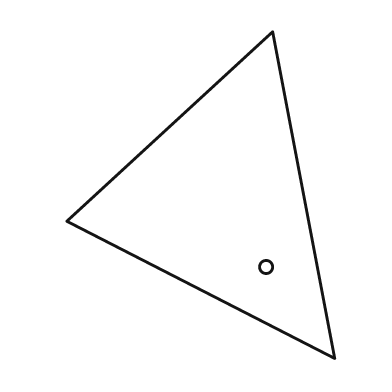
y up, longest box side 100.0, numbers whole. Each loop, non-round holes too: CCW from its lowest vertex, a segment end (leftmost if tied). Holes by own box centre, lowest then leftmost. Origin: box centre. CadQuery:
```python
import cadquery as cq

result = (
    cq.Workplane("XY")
    .moveTo(41.0, -50.0)
    .lineTo(22.0, 50.0)
    .lineTo(-41.0, -8.0)
    .close()
    .moveTo(20.0, -22.0)
    .circle(2.0)
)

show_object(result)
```